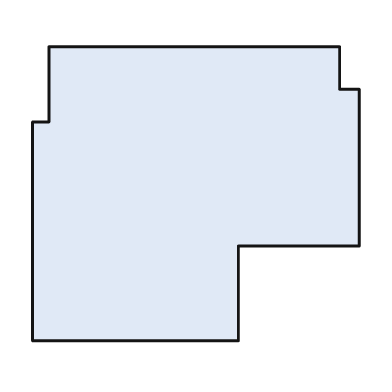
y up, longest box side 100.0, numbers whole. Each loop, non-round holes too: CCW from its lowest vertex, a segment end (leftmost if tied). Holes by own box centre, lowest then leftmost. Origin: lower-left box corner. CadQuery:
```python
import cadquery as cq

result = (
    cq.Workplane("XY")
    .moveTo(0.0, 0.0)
    .lineTo(63.0, 0.0)
    .lineTo(63.0, 29.0)
    .lineTo(100.0, 29.0)
    .lineTo(100.0, 77.0)
    .lineTo(94.0, 77.0)
    .lineTo(94.0, 90.0)
    .lineTo(5.0, 90.0)
    .lineTo(5.0, 67.0)
    .lineTo(0.0, 67.0)
    .close()
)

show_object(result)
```